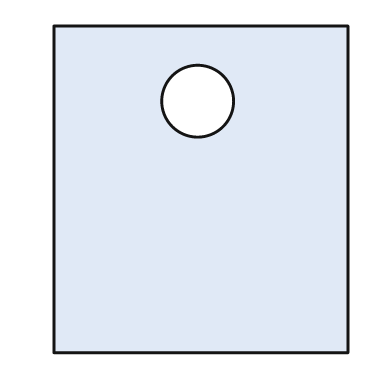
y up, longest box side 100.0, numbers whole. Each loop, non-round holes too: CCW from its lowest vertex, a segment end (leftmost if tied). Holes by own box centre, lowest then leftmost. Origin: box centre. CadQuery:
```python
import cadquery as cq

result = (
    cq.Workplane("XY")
    .moveTo(-45.0, -50.0)
    .lineTo(45.0, -50.0)
    .lineTo(45.0, 50.0)
    .lineTo(-45.0, 50.0)
    .close()
    .moveTo(-1.0, 27.0)
    .circle(11.0)
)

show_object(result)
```